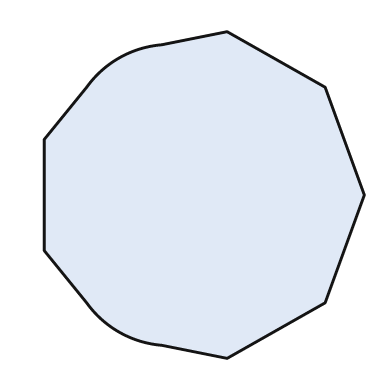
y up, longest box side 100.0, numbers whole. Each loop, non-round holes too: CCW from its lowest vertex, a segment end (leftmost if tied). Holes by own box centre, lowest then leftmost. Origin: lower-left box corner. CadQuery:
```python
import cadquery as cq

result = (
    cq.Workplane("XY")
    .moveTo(56.0, 0.0)
    .lineTo(86.0, 17.0)
    .lineTo(98.0, 50.0)
    .lineTo(86.0, 83.0)
    .lineTo(56.0, 100.0)
    .lineTo(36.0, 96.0)
    .threePointArc((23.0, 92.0), (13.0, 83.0))
    .lineTo(0.0, 67.0)
    .lineTo(0.0, 33.0)
    .lineTo(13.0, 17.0)
    .threePointArc((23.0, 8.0), (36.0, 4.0))
    .close()
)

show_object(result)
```